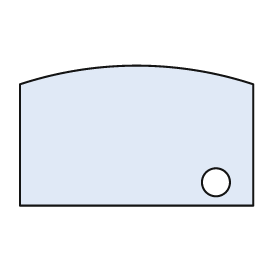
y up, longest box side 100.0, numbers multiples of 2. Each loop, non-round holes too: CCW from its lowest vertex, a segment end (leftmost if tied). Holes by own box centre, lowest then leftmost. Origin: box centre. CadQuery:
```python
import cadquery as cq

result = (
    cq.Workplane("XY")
    .moveTo(-50.0, -30.0)
    .lineTo(50.0, -30.0)
    .lineTo(50.0, 22.0)
    .threePointArc((0.0, 30.0), (-50.0, 22.0))
    .close()
    .moveTo(34.0, -20.0)
    .circle(6.0)
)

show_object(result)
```